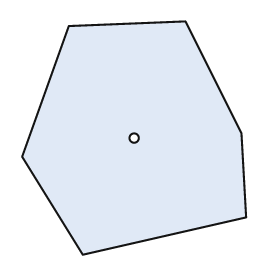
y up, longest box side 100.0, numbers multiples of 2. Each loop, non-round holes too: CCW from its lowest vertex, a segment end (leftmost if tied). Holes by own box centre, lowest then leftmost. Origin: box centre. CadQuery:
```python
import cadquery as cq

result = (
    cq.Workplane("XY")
    .moveTo(-22.0, -50.0)
    .lineTo(48.0, -34.0)
    .lineTo(46.0, 2.0)
    .lineTo(22.0, 50.0)
    .lineTo(-28.0, 48.0)
    .lineTo(-48.0, -8.0)
    .close()
    .moveTo(0.0, 0.0)
    .circle(2.0)
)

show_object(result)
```